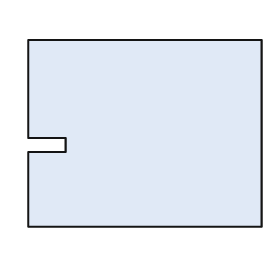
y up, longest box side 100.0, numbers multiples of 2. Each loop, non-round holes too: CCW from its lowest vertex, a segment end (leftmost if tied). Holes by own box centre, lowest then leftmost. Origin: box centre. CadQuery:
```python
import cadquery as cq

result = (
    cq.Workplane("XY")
    .moveTo(-50.0, -40.0)
    .lineTo(50.0, -40.0)
    .lineTo(50.0, 40.0)
    .lineTo(-50.0, 40.0)
    .lineTo(-50.0, -2.0)
    .lineTo(-34.0, -2.0)
    .lineTo(-34.0, -8.0)
    .lineTo(-50.0, -8.0)
    .close()
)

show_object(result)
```